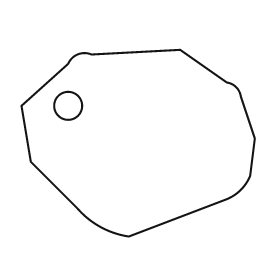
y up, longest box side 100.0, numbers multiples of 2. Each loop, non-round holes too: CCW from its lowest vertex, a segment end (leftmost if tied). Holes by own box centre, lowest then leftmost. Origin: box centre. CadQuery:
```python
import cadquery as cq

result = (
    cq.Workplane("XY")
    .moveTo(-4.0, -40.0)
    .lineTo(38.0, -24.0)
    .threePointArc((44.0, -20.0), (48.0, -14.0))
    .lineTo(50.0, 2.0)
    .lineTo(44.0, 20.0)
    .threePointArc((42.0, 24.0), (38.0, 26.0))
    .lineTo(18.0, 40.0)
    .lineTo(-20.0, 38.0)
    .threePointArc((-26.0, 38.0), (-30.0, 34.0))
    .lineTo(-50.0, 16.0)
    .lineTo(-46.0, -8.0)
    .lineTo(-26.0, -28.0)
    .threePointArc((-16.0, -36.0), (-4.0, -40.0))
    .close()
    .moveTo(-30.0, 16.0)
    .circle(6.0)
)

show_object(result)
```